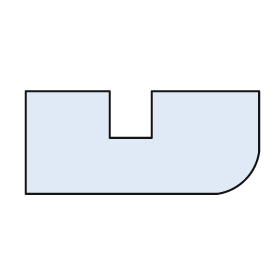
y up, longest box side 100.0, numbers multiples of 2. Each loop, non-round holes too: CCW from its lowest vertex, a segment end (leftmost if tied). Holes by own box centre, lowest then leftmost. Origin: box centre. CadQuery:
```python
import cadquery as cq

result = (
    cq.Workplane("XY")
    .moveTo(-50.0, -22.0)
    .lineTo(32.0, -22.0)
    .threePointArc((44.0, -16.0), (50.0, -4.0))
    .lineTo(50.0, 22.0)
    .lineTo(4.0, 22.0)
    .lineTo(4.0, 2.0)
    .lineTo(-14.0, 2.0)
    .lineTo(-14.0, 22.0)
    .lineTo(-50.0, 22.0)
    .close()
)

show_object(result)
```